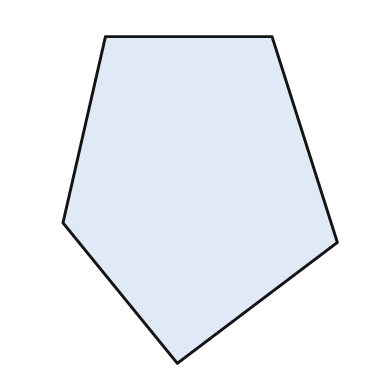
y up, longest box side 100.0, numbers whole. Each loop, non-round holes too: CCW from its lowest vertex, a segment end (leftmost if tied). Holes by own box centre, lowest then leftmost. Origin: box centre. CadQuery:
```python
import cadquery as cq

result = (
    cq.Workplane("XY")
    .moveTo(-7.0, -50.0)
    .lineTo(42.0, -13.0)
    .lineTo(22.0, 50.0)
    .lineTo(-29.0, 50.0)
    .lineTo(-42.0, -7.0)
    .close()
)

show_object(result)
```